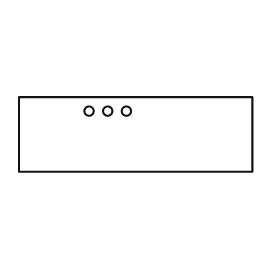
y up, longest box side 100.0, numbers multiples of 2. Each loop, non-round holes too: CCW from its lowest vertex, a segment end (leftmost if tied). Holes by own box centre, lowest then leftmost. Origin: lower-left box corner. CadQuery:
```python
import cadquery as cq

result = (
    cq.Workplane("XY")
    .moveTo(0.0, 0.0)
    .lineTo(100.0, 0.0)
    .lineTo(100.0, 32.0)
    .lineTo(0.0, 32.0)
    .close()
    .moveTo(30.0, 26.0)
    .circle(2.0)
    .moveTo(38.0, 26.0)
    .circle(2.0)
    .moveTo(46.0, 26.0)
    .circle(2.0)
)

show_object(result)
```